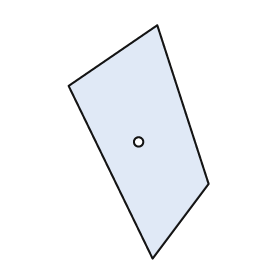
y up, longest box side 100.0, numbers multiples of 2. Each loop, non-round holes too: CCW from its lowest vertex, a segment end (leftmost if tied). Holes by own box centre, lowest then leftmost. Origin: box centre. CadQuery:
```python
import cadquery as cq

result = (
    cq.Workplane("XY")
    .moveTo(6.0, -50.0)
    .lineTo(30.0, -18.0)
    .lineTo(8.0, 50.0)
    .lineTo(-30.0, 24.0)
    .close()
    .moveTo(0.0, 0.0)
    .circle(2.0)
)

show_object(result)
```